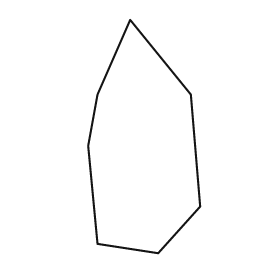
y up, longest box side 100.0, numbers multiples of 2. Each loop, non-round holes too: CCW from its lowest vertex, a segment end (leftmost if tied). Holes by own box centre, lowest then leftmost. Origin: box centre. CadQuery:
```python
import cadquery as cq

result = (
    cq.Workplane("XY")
    .moveTo(6.0, -50.0)
    .lineTo(24.0, -30.0)
    .lineTo(20.0, 18.0)
    .lineTo(-6.0, 50.0)
    .lineTo(-20.0, 18.0)
    .lineTo(-24.0, -4.0)
    .lineTo(-20.0, -46.0)
    .close()
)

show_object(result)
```